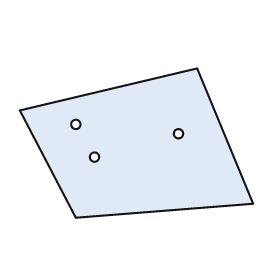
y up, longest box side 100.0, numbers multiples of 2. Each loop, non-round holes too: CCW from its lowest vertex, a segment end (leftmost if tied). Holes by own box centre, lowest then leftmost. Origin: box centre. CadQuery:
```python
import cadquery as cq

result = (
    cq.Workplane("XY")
    .moveTo(-26.0, -32.0)
    .lineTo(50.0, -26.0)
    .lineTo(26.0, 32.0)
    .lineTo(-50.0, 14.0)
    .close()
    .moveTo(-18.0, -6.0)
    .circle(2.0)
    .moveTo(18.0, 4.0)
    .circle(2.0)
    .moveTo(-26.0, 8.0)
    .circle(2.0)
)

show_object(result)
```